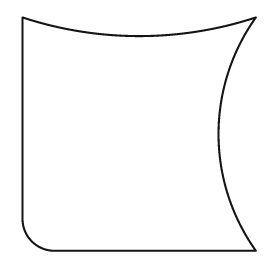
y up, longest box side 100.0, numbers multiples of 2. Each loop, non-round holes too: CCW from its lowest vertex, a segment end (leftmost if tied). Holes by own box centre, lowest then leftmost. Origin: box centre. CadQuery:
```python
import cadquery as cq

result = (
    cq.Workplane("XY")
    .moveTo(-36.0, -50.0)
    .lineTo(50.0, -50.0)
    .threePointArc((34.0, 0.0), (50.0, 50.0))
    .threePointArc((0.0, 42.0), (-50.0, 50.0))
    .lineTo(-50.0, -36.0)
    .threePointArc((-46.0, -46.0), (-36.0, -50.0))
    .close()
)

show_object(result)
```